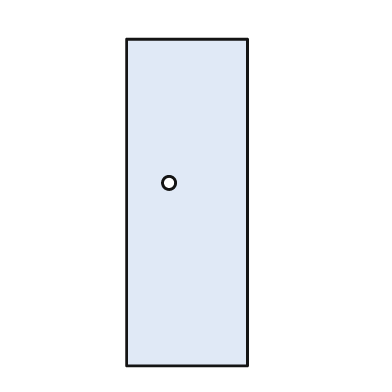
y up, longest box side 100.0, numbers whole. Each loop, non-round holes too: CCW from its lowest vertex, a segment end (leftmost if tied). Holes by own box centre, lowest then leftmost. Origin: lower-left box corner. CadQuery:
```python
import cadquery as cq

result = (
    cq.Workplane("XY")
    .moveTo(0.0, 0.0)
    .lineTo(37.0, 0.0)
    .lineTo(37.0, 100.0)
    .lineTo(0.0, 100.0)
    .close()
    .moveTo(13.0, 56.0)
    .circle(2.0)
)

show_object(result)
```